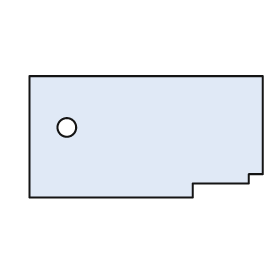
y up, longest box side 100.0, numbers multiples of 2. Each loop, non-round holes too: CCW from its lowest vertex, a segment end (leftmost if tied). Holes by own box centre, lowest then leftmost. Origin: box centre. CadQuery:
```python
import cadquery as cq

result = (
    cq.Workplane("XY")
    .moveTo(-50.0, -26.0)
    .lineTo(20.0, -26.0)
    .lineTo(20.0, -20.0)
    .lineTo(44.0, -20.0)
    .lineTo(44.0, -16.0)
    .lineTo(50.0, -16.0)
    .lineTo(50.0, 26.0)
    .lineTo(-50.0, 26.0)
    .close()
    .moveTo(-34.0, 4.0)
    .circle(4.0)
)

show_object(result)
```